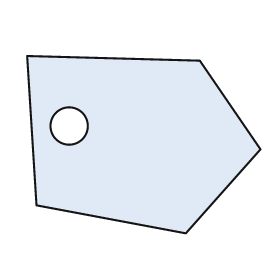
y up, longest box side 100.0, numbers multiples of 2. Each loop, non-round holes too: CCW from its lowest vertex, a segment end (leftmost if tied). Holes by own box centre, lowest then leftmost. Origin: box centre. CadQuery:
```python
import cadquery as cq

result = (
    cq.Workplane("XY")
    .moveTo(18.0, -38.0)
    .lineTo(50.0, -2.0)
    .lineTo(24.0, 36.0)
    .lineTo(-50.0, 38.0)
    .lineTo(-46.0, -26.0)
    .close()
    .moveTo(-32.0, 8.0)
    .circle(8.0)
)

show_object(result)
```